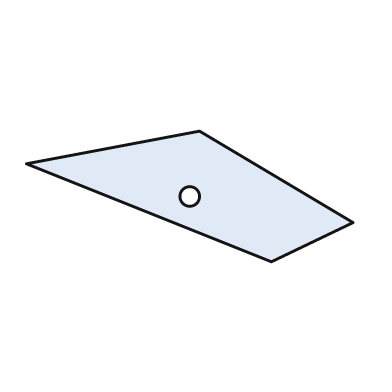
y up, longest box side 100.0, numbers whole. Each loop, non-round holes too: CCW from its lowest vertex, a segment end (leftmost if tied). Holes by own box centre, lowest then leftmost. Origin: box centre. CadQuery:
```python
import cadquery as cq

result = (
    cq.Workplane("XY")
    .moveTo(25.0, -20.0)
    .lineTo(50.0, -8.0)
    .lineTo(3.0, 20.0)
    .lineTo(-50.0, 10.0)
    .close()
    .moveTo(0.0, 0.0)
    .circle(3.0)
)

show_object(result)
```